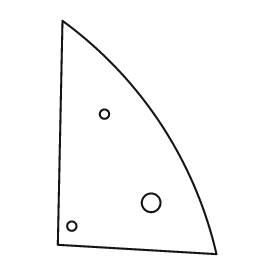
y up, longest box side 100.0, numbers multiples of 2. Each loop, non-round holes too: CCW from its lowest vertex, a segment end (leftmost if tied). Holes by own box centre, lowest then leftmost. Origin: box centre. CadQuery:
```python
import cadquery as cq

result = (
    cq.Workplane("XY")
    .moveTo(34.0, -50.0)
    .threePointArc((10.0, 6.0), (-32.0, 50.0))
    .lineTo(-34.0, -46.0)
    .close()
    .moveTo(-28.0, -38.0)
    .circle(2.0)
    .moveTo(6.0, -28.0)
    .circle(4.0)
    .moveTo(-14.0, 10.0)
    .circle(2.0)
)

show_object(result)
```